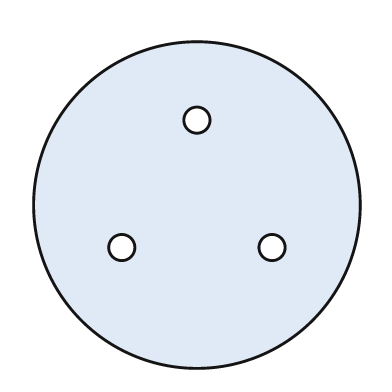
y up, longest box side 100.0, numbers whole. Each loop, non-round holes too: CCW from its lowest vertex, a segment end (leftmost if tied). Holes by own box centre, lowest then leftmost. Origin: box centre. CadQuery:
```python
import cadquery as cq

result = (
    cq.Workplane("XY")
    .moveTo(0.0, 0.0)
    .circle(50.0)
    .moveTo(-23.0, -13.0)
    .circle(4.0)
    .moveTo(23.0, -13.0)
    .circle(4.0)
    .moveTo(0.0, 26.0)
    .circle(4.0)
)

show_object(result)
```